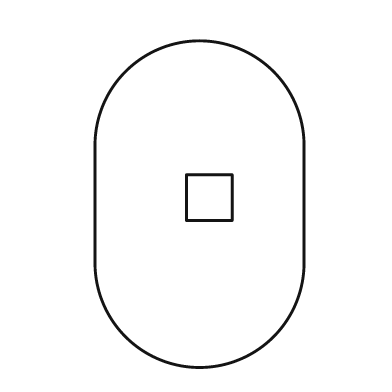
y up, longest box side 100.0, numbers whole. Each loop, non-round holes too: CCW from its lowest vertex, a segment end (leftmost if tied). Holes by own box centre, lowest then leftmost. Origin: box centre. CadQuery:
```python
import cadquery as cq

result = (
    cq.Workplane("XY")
    .moveTo(-32.0, -18.0)
    .threePointArc((0.0, -50.0), (32.0, -18.0))
    .lineTo(32.0, 18.0)
    .threePointArc((0.0, 50.0), (-32.0, 18.0))
    .close()
    .moveTo(-4.0, -5.0)
    .lineTo(10.0, -5.0)
    .lineTo(10.0, 9.0)
    .lineTo(-4.0, 9.0)
    .close()
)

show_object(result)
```